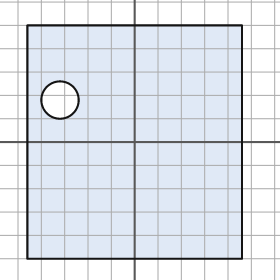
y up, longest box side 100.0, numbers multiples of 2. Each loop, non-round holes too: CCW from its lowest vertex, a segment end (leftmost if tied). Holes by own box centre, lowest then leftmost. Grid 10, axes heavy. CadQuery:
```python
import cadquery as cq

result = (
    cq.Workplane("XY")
    .moveTo(-46.0, -50.0)
    .lineTo(46.0, -50.0)
    .lineTo(46.0, 50.0)
    .lineTo(-46.0, 50.0)
    .close()
    .moveTo(-32.0, 18.0)
    .circle(8.0)
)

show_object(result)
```